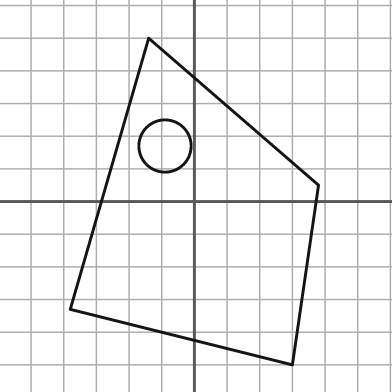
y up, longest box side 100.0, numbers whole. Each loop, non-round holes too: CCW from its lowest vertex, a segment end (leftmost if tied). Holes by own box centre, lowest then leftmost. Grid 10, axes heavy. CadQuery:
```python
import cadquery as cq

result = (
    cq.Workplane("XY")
    .moveTo(30.0, -50.0)
    .lineTo(38.0, 5.0)
    .lineTo(-14.0, 50.0)
    .lineTo(-38.0, -33.0)
    .close()
    .moveTo(-9.0, 17.0)
    .circle(8.0)
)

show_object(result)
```